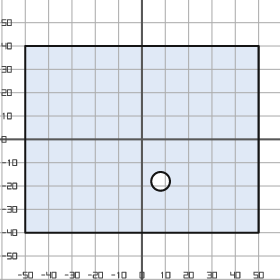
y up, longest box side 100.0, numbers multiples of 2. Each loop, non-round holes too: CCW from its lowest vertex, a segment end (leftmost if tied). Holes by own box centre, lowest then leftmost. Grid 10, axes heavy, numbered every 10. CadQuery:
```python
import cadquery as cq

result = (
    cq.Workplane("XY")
    .moveTo(-50.0, -40.0)
    .lineTo(50.0, -40.0)
    .lineTo(50.0, 40.0)
    .lineTo(-50.0, 40.0)
    .close()
    .moveTo(8.0, -18.0)
    .circle(4.0)
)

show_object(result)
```